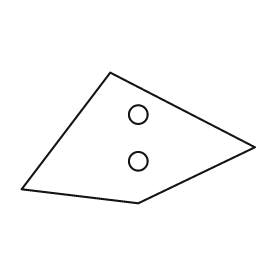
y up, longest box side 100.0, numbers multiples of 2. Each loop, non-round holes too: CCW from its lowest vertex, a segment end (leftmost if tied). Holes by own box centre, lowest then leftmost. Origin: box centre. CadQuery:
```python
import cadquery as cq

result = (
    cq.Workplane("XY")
    .moveTo(0.0, -28.0)
    .lineTo(50.0, -4.0)
    .lineTo(-12.0, 28.0)
    .lineTo(-50.0, -22.0)
    .close()
    .moveTo(0.0, -10.0)
    .circle(4.0)
    .moveTo(0.0, 10.0)
    .circle(4.0)
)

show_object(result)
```